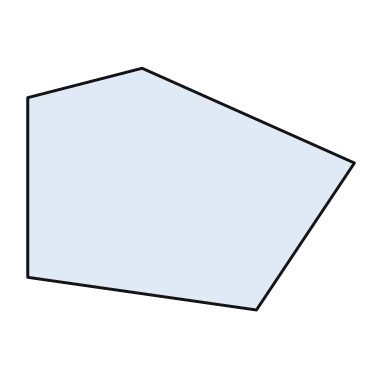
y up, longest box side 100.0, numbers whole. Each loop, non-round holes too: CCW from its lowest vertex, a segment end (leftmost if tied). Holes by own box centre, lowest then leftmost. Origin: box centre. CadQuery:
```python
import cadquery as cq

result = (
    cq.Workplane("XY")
    .moveTo(20.0, -37.0)
    .lineTo(50.0, 8.0)
    .lineTo(-15.0, 37.0)
    .lineTo(-50.0, 28.0)
    .lineTo(-50.0, -27.0)
    .close()
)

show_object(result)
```